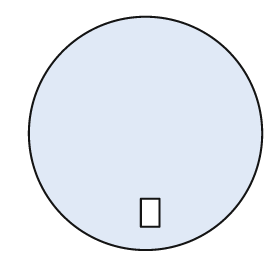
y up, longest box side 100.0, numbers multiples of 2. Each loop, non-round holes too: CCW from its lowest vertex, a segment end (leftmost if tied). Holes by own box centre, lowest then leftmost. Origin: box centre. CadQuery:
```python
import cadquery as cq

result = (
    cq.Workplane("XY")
    .moveTo(0.0, 0.0)
    .circle(50.0)
    .moveTo(-2.0, -40.0)
    .lineTo(6.0, -40.0)
    .lineTo(6.0, -28.0)
    .lineTo(-2.0, -28.0)
    .close()
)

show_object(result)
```